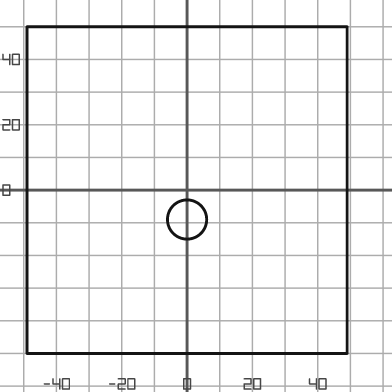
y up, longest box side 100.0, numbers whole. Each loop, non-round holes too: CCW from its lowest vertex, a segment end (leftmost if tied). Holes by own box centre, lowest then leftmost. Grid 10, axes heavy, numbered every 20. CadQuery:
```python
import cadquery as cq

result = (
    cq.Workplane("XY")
    .moveTo(-49.0, -50.0)
    .lineTo(49.0, -50.0)
    .lineTo(49.0, 50.0)
    .lineTo(-49.0, 50.0)
    .close()
    .moveTo(0.0, -9.0)
    .circle(6.0)
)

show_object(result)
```